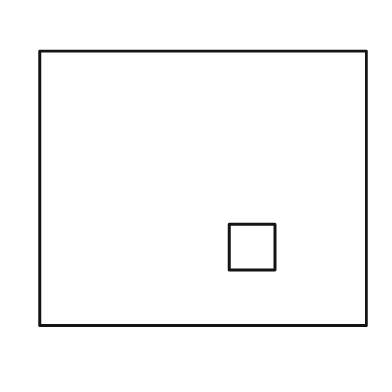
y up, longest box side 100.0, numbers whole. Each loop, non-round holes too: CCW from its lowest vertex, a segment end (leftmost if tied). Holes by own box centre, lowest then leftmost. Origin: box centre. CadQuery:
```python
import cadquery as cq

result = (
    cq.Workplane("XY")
    .moveTo(-50.0, -42.0)
    .lineTo(50.0, -42.0)
    .lineTo(50.0, 42.0)
    .lineTo(-50.0, 42.0)
    .close()
    .moveTo(8.0, -25.0)
    .lineTo(22.0, -25.0)
    .lineTo(22.0, -11.0)
    .lineTo(8.0, -11.0)
    .close()
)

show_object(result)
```